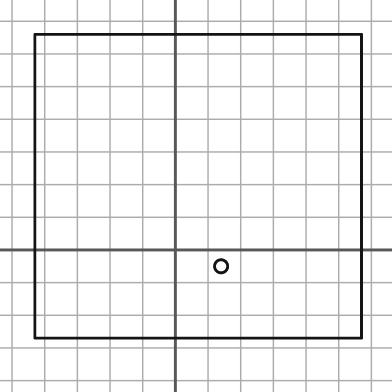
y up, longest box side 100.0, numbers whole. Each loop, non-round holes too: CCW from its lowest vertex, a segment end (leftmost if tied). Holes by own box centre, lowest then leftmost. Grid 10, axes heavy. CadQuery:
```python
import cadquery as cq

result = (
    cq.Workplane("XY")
    .moveTo(-43.0, -27.0)
    .lineTo(57.0, -27.0)
    .lineTo(57.0, 66.0)
    .lineTo(-43.0, 66.0)
    .close()
    .moveTo(14.0, -5.0)
    .circle(2.0)
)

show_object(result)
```